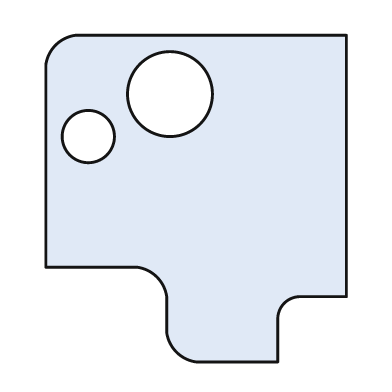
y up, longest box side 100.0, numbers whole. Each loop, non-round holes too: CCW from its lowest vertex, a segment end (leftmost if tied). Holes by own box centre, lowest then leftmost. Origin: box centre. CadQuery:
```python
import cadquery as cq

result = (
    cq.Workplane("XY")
    .moveTo(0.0, -50.0)
    .lineTo(25.0, -50.0)
    .lineTo(25.0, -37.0)
    .threePointArc((27.0, -32.0), (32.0, -30.0))
    .lineTo(46.0, -30.0)
    .lineTo(46.0, 50.0)
    .lineTo(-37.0, 50.0)
    .threePointArc((-43.0, 47.0), (-46.0, 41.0))
    .lineTo(-46.0, -21.0)
    .lineTo(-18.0, -21.0)
    .threePointArc((-12.0, -24.0), (-9.0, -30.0))
    .lineTo(-9.0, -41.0)
    .threePointArc((-6.0, -47.0), (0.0, -50.0))
    .close()
    .moveTo(-33.0, 19.0)
    .circle(8.0)
    .moveTo(-8.0, 32.0)
    .circle(13.0)
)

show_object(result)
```